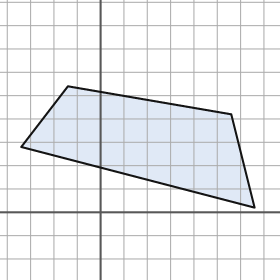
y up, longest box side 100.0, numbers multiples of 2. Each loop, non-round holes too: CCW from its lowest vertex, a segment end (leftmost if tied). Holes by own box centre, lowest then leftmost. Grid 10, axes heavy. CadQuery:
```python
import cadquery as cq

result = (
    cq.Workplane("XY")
    .moveTo(66.0, 2.0)
    .lineTo(56.0, 42.0)
    .lineTo(-14.0, 54.0)
    .lineTo(-34.0, 28.0)
    .close()
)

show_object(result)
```